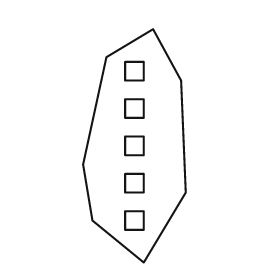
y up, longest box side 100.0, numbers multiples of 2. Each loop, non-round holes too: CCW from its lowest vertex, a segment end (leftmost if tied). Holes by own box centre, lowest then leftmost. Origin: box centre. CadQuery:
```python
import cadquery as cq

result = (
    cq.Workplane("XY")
    .moveTo(4.0, -50.0)
    .lineTo(22.0, -20.0)
    .lineTo(20.0, 28.0)
    .lineTo(8.0, 50.0)
    .lineTo(-12.0, 38.0)
    .lineTo(-22.0, -8.0)
    .lineTo(-18.0, -32.0)
    .close()
    .moveTo(-4.0, -36.0)
    .lineTo(4.0, -36.0)
    .lineTo(4.0, -28.0)
    .lineTo(-4.0, -28.0)
    .close()
    .moveTo(-4.0, -20.0)
    .lineTo(4.0, -20.0)
    .lineTo(4.0, -12.0)
    .lineTo(-4.0, -12.0)
    .close()
    .moveTo(-4.0, -4.0)
    .lineTo(4.0, -4.0)
    .lineTo(4.0, 4.0)
    .lineTo(-4.0, 4.0)
    .close()
    .moveTo(-4.0, 12.0)
    .lineTo(4.0, 12.0)
    .lineTo(4.0, 20.0)
    .lineTo(-4.0, 20.0)
    .close()
    .moveTo(-4.0, 28.0)
    .lineTo(4.0, 28.0)
    .lineTo(4.0, 36.0)
    .lineTo(-4.0, 36.0)
    .close()
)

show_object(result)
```